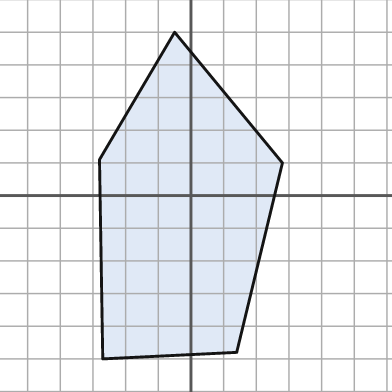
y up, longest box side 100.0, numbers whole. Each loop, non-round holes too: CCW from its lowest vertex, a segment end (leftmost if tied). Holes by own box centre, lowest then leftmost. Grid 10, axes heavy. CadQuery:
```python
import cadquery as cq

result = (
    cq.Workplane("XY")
    .moveTo(-27.0, -50.0)
    .lineTo(14.0, -48.0)
    .lineTo(28.0, 10.0)
    .lineTo(-5.0, 50.0)
    .lineTo(-28.0, 11.0)
    .close()
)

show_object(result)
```